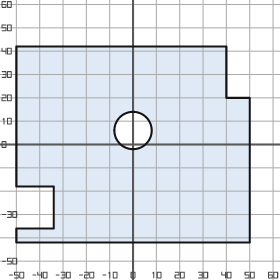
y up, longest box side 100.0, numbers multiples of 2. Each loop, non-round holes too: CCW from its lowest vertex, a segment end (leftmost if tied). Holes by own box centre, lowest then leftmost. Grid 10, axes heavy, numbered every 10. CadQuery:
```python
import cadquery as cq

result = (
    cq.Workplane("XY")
    .moveTo(-50.0, -42.0)
    .lineTo(50.0, -42.0)
    .lineTo(50.0, 20.0)
    .lineTo(40.0, 20.0)
    .lineTo(40.0, 42.0)
    .lineTo(-50.0, 42.0)
    .lineTo(-50.0, -18.0)
    .lineTo(-34.0, -18.0)
    .lineTo(-34.0, -36.0)
    .lineTo(-50.0, -36.0)
    .close()
    .moveTo(0.0, 6.0)
    .circle(8.0)
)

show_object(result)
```